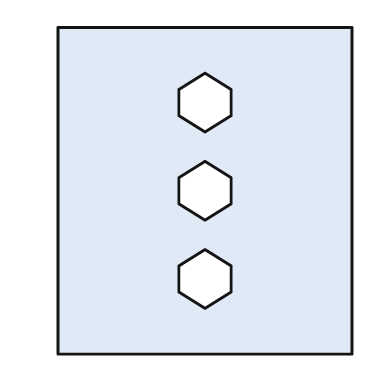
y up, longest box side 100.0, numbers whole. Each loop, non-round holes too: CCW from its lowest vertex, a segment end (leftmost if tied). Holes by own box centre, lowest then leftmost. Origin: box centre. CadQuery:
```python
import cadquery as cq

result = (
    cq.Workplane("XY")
    .moveTo(-45.0, -50.0)
    .lineTo(45.0, -50.0)
    .lineTo(45.0, 50.0)
    .lineTo(-45.0, 50.0)
    .close()
    .moveTo(0.0, -36.0)
    .lineTo(8.0, -31.0)
    .lineTo(8.0, -23.0)
    .lineTo(0.0, -18.0)
    .lineTo(-8.0, -23.0)
    .lineTo(-8.0, -31.0)
    .close()
    .moveTo(0.0, -9.0)
    .lineTo(8.0, -4.0)
    .lineTo(8.0, 4.0)
    .lineTo(0.0, 9.0)
    .lineTo(-8.0, 4.0)
    .lineTo(-8.0, -4.0)
    .close()
    .moveTo(0.0, 18.0)
    .lineTo(8.0, 23.0)
    .lineTo(8.0, 31.0)
    .lineTo(0.0, 36.0)
    .lineTo(-8.0, 31.0)
    .lineTo(-8.0, 23.0)
    .close()
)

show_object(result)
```